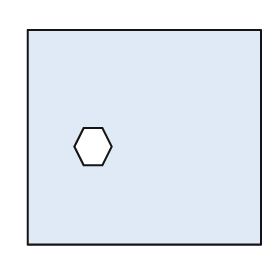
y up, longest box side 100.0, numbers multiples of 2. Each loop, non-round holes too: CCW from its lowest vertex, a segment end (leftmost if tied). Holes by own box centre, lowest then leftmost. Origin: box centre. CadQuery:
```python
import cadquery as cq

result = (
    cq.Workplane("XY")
    .moveTo(-50.0, -46.0)
    .lineTo(50.0, -46.0)
    .lineTo(50.0, 46.0)
    .lineTo(-50.0, 46.0)
    .close()
    .moveTo(-26.0, -12.0)
    .lineTo(-18.0, -12.0)
    .lineTo(-14.0, -4.0)
    .lineTo(-18.0, 4.0)
    .lineTo(-26.0, 4.0)
    .lineTo(-30.0, -4.0)
    .close()
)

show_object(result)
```